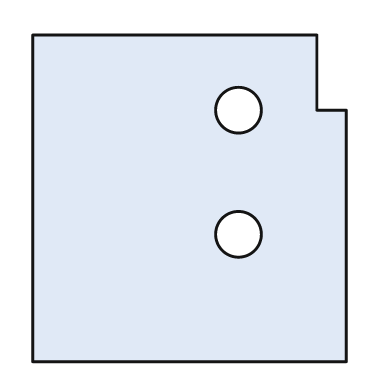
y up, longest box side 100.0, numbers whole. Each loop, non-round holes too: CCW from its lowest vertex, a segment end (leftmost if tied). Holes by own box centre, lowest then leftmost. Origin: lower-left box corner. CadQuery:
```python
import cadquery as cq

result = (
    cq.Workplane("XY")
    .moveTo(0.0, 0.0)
    .lineTo(96.0, 0.0)
    .lineTo(96.0, 77.0)
    .lineTo(87.0, 77.0)
    .lineTo(87.0, 100.0)
    .lineTo(0.0, 100.0)
    .close()
    .moveTo(63.0, 39.0)
    .circle(7.0)
    .moveTo(63.0, 77.0)
    .circle(7.0)
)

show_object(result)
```